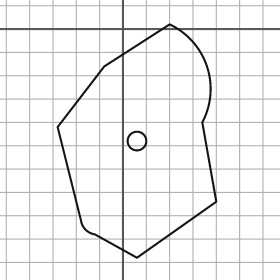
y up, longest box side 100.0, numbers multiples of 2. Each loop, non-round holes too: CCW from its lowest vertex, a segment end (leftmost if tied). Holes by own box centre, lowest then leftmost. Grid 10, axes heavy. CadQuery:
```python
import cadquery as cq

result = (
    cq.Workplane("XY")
    .moveTo(6.0, -98.0)
    .lineTo(40.0, -74.0)
    .lineTo(34.0, -40.0)
    .threePointArc((36.0, -16.0), (20.0, 2.0))
    .lineTo(-8.0, -16.0)
    .lineTo(-28.0, -42.0)
    .lineTo(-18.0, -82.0)
    .threePointArc((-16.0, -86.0), (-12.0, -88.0))
    .close()
    .moveTo(6.0, -48.0)
    .circle(4.0)
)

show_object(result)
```